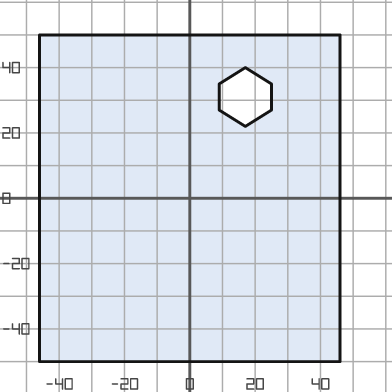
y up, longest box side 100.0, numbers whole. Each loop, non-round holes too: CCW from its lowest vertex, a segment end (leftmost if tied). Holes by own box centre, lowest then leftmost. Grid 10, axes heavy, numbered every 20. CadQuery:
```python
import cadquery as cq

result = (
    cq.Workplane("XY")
    .moveTo(-46.0, -50.0)
    .lineTo(46.0, -50.0)
    .lineTo(46.0, 50.0)
    .lineTo(-46.0, 50.0)
    .close()
    .moveTo(17.0, 22.0)
    .lineTo(25.0, 27.0)
    .lineTo(25.0, 35.0)
    .lineTo(17.0, 40.0)
    .lineTo(9.0, 35.0)
    .lineTo(9.0, 27.0)
    .close()
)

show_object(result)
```